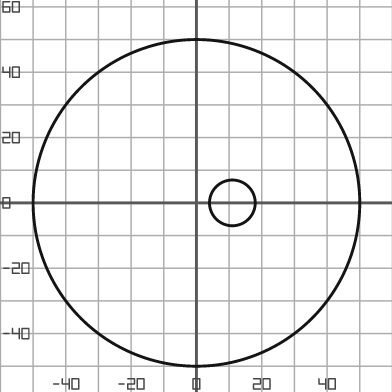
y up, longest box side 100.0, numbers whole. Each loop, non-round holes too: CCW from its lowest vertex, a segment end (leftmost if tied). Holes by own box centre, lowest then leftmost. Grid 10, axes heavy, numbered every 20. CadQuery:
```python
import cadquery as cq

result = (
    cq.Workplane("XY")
    .moveTo(0.0, 0.0)
    .circle(50.0)
    .moveTo(11.0, 0.0)
    .circle(7.0)
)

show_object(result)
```